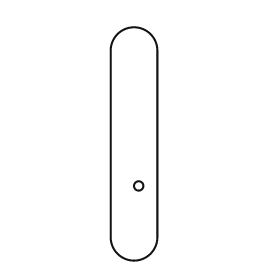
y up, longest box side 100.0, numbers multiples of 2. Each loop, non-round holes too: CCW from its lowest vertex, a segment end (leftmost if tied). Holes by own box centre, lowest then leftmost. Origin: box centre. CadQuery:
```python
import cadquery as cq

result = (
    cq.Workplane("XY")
    .moveTo(-10.0, -40.0)
    .threePointArc((0.0, -50.0), (10.0, -40.0))
    .lineTo(10.0, 40.0)
    .threePointArc((0.0, 50.0), (-10.0, 40.0))
    .close()
    .moveTo(2.0, -18.0)
    .circle(2.0)
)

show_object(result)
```